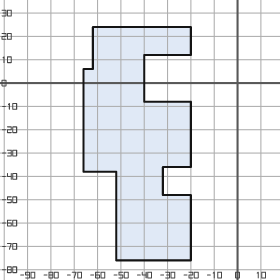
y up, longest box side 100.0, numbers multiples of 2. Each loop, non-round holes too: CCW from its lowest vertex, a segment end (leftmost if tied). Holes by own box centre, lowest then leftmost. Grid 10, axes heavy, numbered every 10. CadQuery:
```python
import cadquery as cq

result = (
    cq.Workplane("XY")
    .moveTo(-52.0, -76.0)
    .lineTo(-20.0, -76.0)
    .lineTo(-20.0, -48.0)
    .lineTo(-32.0, -48.0)
    .lineTo(-32.0, -36.0)
    .lineTo(-20.0, -36.0)
    .lineTo(-20.0, -8.0)
    .lineTo(-40.0, -8.0)
    .lineTo(-40.0, 12.0)
    .lineTo(-20.0, 12.0)
    .lineTo(-20.0, 24.0)
    .lineTo(-62.0, 24.0)
    .lineTo(-62.0, 6.0)
    .lineTo(-66.0, 6.0)
    .lineTo(-66.0, -38.0)
    .lineTo(-52.0, -38.0)
    .close()
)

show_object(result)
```